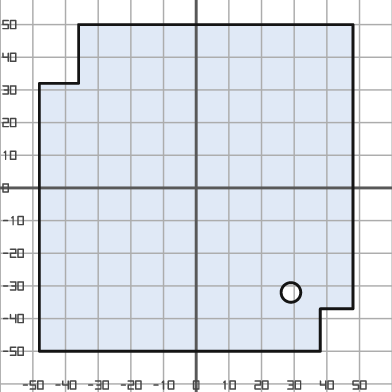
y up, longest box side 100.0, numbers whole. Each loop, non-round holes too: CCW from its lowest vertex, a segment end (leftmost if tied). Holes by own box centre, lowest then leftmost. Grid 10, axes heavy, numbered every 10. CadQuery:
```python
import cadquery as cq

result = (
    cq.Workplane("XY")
    .moveTo(-48.0, -50.0)
    .lineTo(38.0, -50.0)
    .lineTo(38.0, -37.0)
    .lineTo(48.0, -37.0)
    .lineTo(48.0, 50.0)
    .lineTo(-36.0, 50.0)
    .lineTo(-36.0, 32.0)
    .lineTo(-48.0, 32.0)
    .close()
    .moveTo(29.0, -32.0)
    .circle(3.0)
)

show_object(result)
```